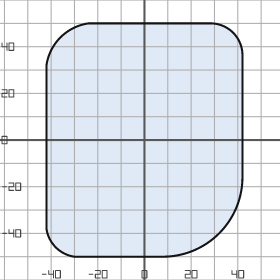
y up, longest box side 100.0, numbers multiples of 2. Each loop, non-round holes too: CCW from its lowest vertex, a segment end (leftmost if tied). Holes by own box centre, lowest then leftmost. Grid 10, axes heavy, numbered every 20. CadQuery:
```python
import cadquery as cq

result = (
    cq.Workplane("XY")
    .moveTo(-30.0, -50.0)
    .lineTo(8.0, -50.0)
    .threePointArc((32.0, -40.0), (42.0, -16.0))
    .lineTo(42.0, 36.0)
    .threePointArc((38.0, 46.0), (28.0, 50.0))
    .lineTo(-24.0, 50.0)
    .threePointArc((-36.0, 44.0), (-42.0, 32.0))
    .lineTo(-42.0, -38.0)
    .threePointArc((-38.0, -46.0), (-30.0, -50.0))
    .close()
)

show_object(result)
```